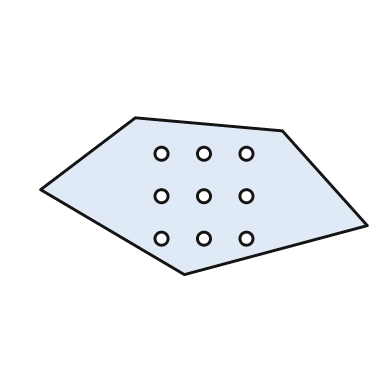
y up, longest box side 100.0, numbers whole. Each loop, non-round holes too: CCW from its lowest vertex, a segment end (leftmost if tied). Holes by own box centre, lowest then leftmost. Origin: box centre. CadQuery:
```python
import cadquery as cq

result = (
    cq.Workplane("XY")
    .moveTo(-6.0, -24.0)
    .lineTo(50.0, -9.0)
    .lineTo(24.0, 20.0)
    .lineTo(-21.0, 24.0)
    .lineTo(-50.0, 2.0)
    .close()
    .moveTo(-13.0, -13.0)
    .circle(2.0)
    .moveTo(0.0, -13.0)
    .circle(2.0)
    .moveTo(13.0, -13.0)
    .circle(2.0)
    .moveTo(-13.0, 0.0)
    .circle(2.0)
    .moveTo(0.0, 0.0)
    .circle(2.0)
    .moveTo(13.0, 0.0)
    .circle(2.0)
    .moveTo(-13.0, 13.0)
    .circle(2.0)
    .moveTo(0.0, 13.0)
    .circle(2.0)
    .moveTo(13.0, 13.0)
    .circle(2.0)
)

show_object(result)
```